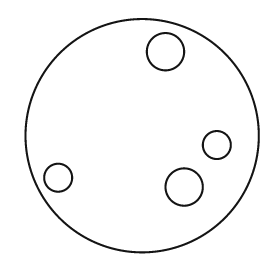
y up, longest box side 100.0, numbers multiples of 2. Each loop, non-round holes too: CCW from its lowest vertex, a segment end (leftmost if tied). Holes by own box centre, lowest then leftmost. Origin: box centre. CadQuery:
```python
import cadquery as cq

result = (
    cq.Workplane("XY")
    .moveTo(0.0, 0.0)
    .circle(50.0)
    .moveTo(18.0, -22.0)
    .circle(8.0)
    .moveTo(-36.0, -18.0)
    .circle(6.0)
    .moveTo(32.0, -4.0)
    .circle(6.0)
    .moveTo(10.0, 36.0)
    .circle(8.0)
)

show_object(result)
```